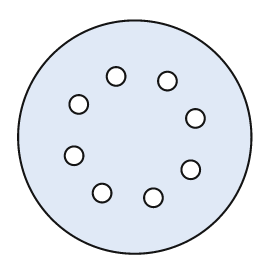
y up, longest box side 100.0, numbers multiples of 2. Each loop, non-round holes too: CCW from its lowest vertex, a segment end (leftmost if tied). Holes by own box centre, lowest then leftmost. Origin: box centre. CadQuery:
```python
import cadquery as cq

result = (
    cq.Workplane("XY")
    .moveTo(0.0, 0.0)
    .circle(50.0)
    .moveTo(8.0, -26.0)
    .circle(4.0)
    .moveTo(-14.0, -24.0)
    .circle(4.0)
    .moveTo(24.0, -14.0)
    .circle(4.0)
    .moveTo(-26.0, -8.0)
    .circle(4.0)
    .moveTo(26.0, 8.0)
    .circle(4.0)
    .moveTo(-24.0, 14.0)
    .circle(4.0)
    .moveTo(14.0, 24.0)
    .circle(4.0)
    .moveTo(-8.0, 26.0)
    .circle(4.0)
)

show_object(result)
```